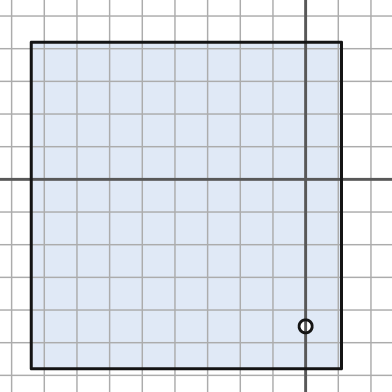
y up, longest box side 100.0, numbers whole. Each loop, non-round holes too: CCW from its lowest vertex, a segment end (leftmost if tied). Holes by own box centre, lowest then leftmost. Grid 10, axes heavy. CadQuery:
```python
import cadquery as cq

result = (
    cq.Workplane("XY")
    .moveTo(-84.0, -58.0)
    .lineTo(11.0, -58.0)
    .lineTo(11.0, 42.0)
    .lineTo(-84.0, 42.0)
    .close()
    .moveTo(0.0, -45.0)
    .circle(2.0)
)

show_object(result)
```